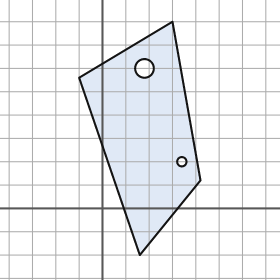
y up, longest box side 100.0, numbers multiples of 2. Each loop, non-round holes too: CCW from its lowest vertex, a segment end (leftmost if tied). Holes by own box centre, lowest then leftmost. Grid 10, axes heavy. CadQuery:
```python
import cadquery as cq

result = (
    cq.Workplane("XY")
    .moveTo(16.0, -20.0)
    .lineTo(42.0, 12.0)
    .lineTo(30.0, 80.0)
    .lineTo(-10.0, 56.0)
    .close()
    .moveTo(34.0, 20.0)
    .circle(2.0)
    .moveTo(18.0, 60.0)
    .circle(4.0)
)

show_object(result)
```